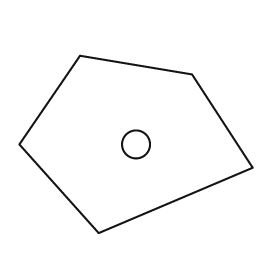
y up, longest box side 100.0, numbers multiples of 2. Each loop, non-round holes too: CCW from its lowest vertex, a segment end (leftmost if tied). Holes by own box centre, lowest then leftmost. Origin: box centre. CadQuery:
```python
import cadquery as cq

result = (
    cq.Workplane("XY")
    .moveTo(-16.0, -38.0)
    .lineTo(50.0, -10.0)
    .lineTo(24.0, 30.0)
    .lineTo(-24.0, 38.0)
    .lineTo(-50.0, 0.0)
    .close()
    .moveTo(0.0, 0.0)
    .circle(6.0)
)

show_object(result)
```